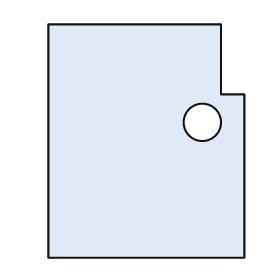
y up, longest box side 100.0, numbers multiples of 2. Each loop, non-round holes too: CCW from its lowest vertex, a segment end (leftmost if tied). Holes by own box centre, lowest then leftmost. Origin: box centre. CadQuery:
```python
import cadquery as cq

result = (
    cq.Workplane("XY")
    .moveTo(-42.0, -50.0)
    .lineTo(42.0, -50.0)
    .lineTo(42.0, 20.0)
    .lineTo(32.0, 20.0)
    .lineTo(32.0, 50.0)
    .lineTo(-42.0, 50.0)
    .close()
    .moveTo(24.0, 8.0)
    .circle(8.0)
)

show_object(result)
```